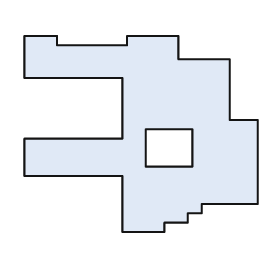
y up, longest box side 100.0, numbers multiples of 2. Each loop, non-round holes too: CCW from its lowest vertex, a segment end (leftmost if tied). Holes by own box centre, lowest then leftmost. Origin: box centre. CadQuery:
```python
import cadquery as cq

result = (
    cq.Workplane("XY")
    .moveTo(-8.0, -42.0)
    .lineTo(10.0, -42.0)
    .lineTo(10.0, -38.0)
    .lineTo(20.0, -38.0)
    .lineTo(20.0, -34.0)
    .lineTo(26.0, -34.0)
    .lineTo(26.0, -30.0)
    .lineTo(50.0, -30.0)
    .lineTo(50.0, 6.0)
    .lineTo(38.0, 6.0)
    .lineTo(38.0, 32.0)
    .lineTo(16.0, 32.0)
    .lineTo(16.0, 42.0)
    .lineTo(-6.0, 42.0)
    .lineTo(-6.0, 38.0)
    .lineTo(-36.0, 38.0)
    .lineTo(-36.0, 42.0)
    .lineTo(-50.0, 42.0)
    .lineTo(-50.0, 24.0)
    .lineTo(-8.0, 24.0)
    .lineTo(-8.0, -2.0)
    .lineTo(-50.0, -2.0)
    .lineTo(-50.0, -18.0)
    .lineTo(-8.0, -18.0)
    .close()
    .moveTo(2.0, -14.0)
    .lineTo(22.0, -14.0)
    .lineTo(22.0, 2.0)
    .lineTo(2.0, 2.0)
    .close()
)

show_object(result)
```